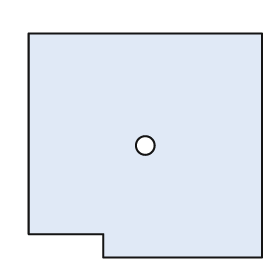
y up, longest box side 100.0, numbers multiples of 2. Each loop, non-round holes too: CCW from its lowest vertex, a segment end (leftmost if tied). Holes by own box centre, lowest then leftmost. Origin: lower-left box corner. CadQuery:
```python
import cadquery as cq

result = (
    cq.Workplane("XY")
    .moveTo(32.0, 0.0)
    .lineTo(100.0, 0.0)
    .lineTo(100.0, 96.0)
    .lineTo(0.0, 96.0)
    .lineTo(0.0, 10.0)
    .lineTo(32.0, 10.0)
    .close()
    .moveTo(50.0, 48.0)
    .circle(4.0)
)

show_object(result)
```